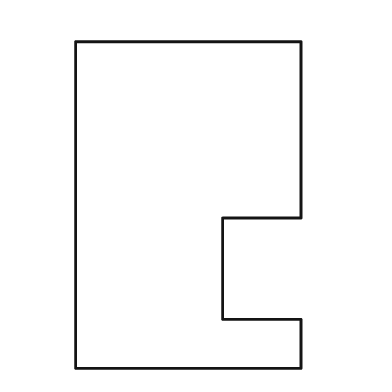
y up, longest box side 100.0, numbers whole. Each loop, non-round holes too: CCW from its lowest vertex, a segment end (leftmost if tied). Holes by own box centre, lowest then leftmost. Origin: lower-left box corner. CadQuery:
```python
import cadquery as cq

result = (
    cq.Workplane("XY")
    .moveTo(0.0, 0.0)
    .lineTo(69.0, 0.0)
    .lineTo(69.0, 15.0)
    .lineTo(45.0, 15.0)
    .lineTo(45.0, 46.0)
    .lineTo(69.0, 46.0)
    .lineTo(69.0, 100.0)
    .lineTo(0.0, 100.0)
    .close()
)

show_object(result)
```